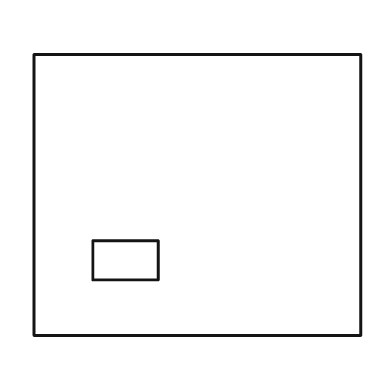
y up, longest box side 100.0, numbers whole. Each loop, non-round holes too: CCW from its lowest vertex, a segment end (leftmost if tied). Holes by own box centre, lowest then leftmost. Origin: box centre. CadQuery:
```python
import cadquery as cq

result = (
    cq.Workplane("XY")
    .moveTo(-50.0, -43.0)
    .lineTo(50.0, -43.0)
    .lineTo(50.0, 43.0)
    .lineTo(-50.0, 43.0)
    .close()
    .moveTo(-32.0, -26.0)
    .lineTo(-12.0, -26.0)
    .lineTo(-12.0, -14.0)
    .lineTo(-32.0, -14.0)
    .close()
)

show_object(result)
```